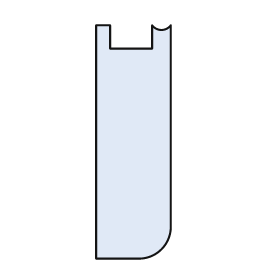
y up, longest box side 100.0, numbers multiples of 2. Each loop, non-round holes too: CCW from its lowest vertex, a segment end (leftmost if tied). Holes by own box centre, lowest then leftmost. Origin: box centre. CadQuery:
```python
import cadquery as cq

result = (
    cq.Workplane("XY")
    .moveTo(-16.0, -50.0)
    .lineTo(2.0, -50.0)
    .threePointArc((12.0, -46.0), (16.0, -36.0))
    .lineTo(16.0, 50.0)
    .threePointArc((12.0, 48.0), (8.0, 50.0))
    .lineTo(8.0, 40.0)
    .lineTo(-10.0, 40.0)
    .lineTo(-10.0, 50.0)
    .lineTo(-16.0, 50.0)
    .close()
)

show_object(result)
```